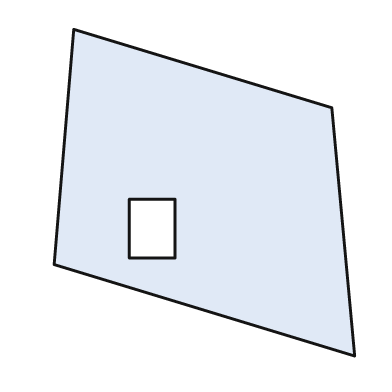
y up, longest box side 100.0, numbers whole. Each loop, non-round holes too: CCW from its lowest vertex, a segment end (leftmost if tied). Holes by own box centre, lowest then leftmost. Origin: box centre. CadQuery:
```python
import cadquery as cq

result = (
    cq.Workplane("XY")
    .moveTo(46.0, -50.0)
    .lineTo(39.0, 26.0)
    .lineTo(-40.0, 50.0)
    .lineTo(-46.0, -22.0)
    .close()
    .moveTo(-23.0, -20.0)
    .lineTo(-9.0, -20.0)
    .lineTo(-9.0, -2.0)
    .lineTo(-23.0, -2.0)
    .close()
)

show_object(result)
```